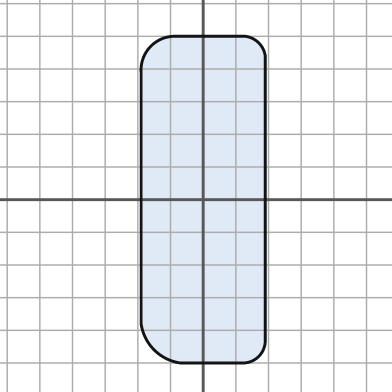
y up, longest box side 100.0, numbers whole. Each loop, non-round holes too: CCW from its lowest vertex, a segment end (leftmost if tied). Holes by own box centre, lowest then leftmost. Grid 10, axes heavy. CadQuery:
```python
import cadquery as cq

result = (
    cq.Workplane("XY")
    .moveTo(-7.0, -50.0)
    .lineTo(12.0, -50.0)
    .threePointArc((17.0, -48.0), (19.0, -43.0))
    .lineTo(19.0, 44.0)
    .threePointArc((17.0, 48.0), (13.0, 50.0))
    .lineTo(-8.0, 50.0)
    .threePointArc((-16.0, 47.0), (-19.0, 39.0))
    .lineTo(-19.0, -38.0)
    .threePointArc((-15.0, -46.0), (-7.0, -50.0))
    .close()
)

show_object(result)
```